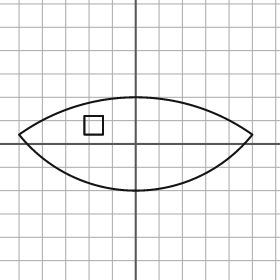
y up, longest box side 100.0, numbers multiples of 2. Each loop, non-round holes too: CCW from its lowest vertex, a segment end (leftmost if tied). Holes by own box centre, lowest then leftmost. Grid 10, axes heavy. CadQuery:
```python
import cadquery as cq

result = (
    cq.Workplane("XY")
    .moveTo(-50.0, 4.0)
    .threePointArc((0.0, -20.0), (50.0, 4.0))
    .threePointArc((0.0, 20.0), (-50.0, 4.0))
    .close()
    .moveTo(-22.0, 4.0)
    .lineTo(-14.0, 4.0)
    .lineTo(-14.0, 12.0)
    .lineTo(-22.0, 12.0)
    .close()
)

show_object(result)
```